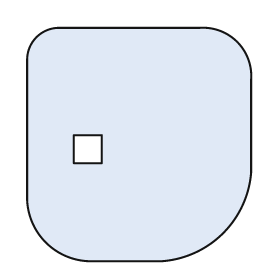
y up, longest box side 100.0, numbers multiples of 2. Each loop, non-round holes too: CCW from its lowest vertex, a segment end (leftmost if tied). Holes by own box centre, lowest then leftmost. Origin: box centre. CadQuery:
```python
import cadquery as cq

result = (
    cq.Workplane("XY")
    .moveTo(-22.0, -50.0)
    .lineTo(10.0, -50.0)
    .threePointArc((36.0, -38.0), (48.0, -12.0))
    .lineTo(48.0, 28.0)
    .threePointArc((42.0, 44.0), (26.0, 50.0))
    .lineTo(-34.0, 50.0)
    .threePointArc((-44.0, 46.0), (-48.0, 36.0))
    .lineTo(-48.0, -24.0)
    .threePointArc((-40.0, -42.0), (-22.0, -50.0))
    .close()
    .moveTo(-28.0, -8.0)
    .lineTo(-16.0, -8.0)
    .lineTo(-16.0, 4.0)
    .lineTo(-28.0, 4.0)
    .close()
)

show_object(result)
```